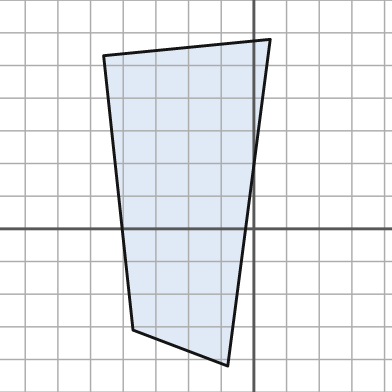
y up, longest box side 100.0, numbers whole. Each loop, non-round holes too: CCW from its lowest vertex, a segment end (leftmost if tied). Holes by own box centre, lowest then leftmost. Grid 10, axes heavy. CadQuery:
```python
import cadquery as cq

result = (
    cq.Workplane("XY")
    .moveTo(-8.0, -42.0)
    .lineTo(5.0, 58.0)
    .lineTo(-46.0, 53.0)
    .lineTo(-37.0, -31.0)
    .close()
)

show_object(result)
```